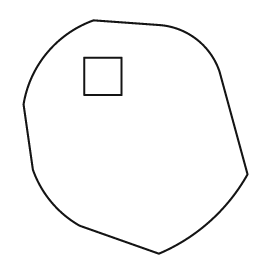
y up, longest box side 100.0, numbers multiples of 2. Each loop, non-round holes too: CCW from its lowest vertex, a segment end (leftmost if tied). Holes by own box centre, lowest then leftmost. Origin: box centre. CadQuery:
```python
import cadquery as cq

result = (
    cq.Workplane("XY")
    .moveTo(10.0, -50.0)
    .threePointArc((32.0, -36.0), (48.0, -16.0))
    .lineTo(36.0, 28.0)
    .threePointArc((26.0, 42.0), (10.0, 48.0))
    .lineTo(-18.0, 50.0)
    .threePointArc((-38.0, 36.0), (-48.0, 14.0))
    .lineTo(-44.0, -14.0)
    .threePointArc((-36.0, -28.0), (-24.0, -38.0))
    .close()
    .moveTo(-22.0, 18.0)
    .lineTo(-6.0, 18.0)
    .lineTo(-6.0, 34.0)
    .lineTo(-22.0, 34.0)
    .close()
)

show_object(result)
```